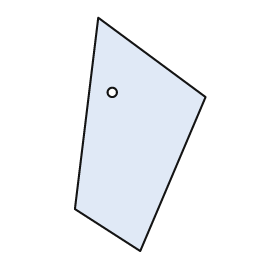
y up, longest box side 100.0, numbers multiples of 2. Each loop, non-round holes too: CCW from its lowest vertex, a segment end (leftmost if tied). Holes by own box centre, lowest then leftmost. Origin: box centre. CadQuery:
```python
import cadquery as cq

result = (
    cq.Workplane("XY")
    .moveTo(0.0, -50.0)
    .lineTo(28.0, 16.0)
    .lineTo(-18.0, 50.0)
    .lineTo(-28.0, -32.0)
    .close()
    .moveTo(-12.0, 18.0)
    .circle(2.0)
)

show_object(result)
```